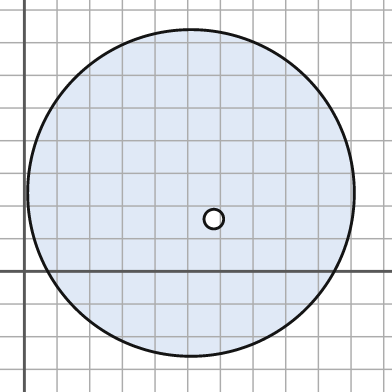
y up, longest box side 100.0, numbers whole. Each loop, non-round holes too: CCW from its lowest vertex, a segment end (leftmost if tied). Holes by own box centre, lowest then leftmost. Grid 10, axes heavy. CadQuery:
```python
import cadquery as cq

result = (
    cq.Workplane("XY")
    .moveTo(51.0, 24.0)
    .circle(50.0)
    .moveTo(58.0, 16.0)
    .circle(3.0)
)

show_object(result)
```